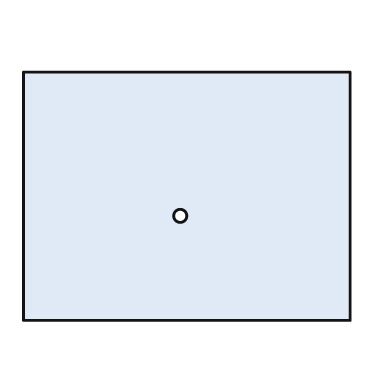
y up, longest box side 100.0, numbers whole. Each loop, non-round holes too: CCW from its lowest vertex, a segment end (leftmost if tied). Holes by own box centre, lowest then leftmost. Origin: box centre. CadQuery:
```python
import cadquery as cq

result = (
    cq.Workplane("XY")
    .moveTo(-50.0, -38.0)
    .lineTo(50.0, -38.0)
    .lineTo(50.0, 38.0)
    .lineTo(-50.0, 38.0)
    .close()
    .moveTo(-2.0, -6.0)
    .circle(2.0)
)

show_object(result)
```